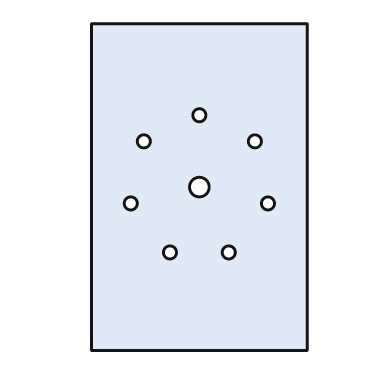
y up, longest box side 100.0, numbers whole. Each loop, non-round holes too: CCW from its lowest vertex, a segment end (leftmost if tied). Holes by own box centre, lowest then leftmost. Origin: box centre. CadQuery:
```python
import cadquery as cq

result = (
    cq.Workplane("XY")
    .moveTo(-33.0, -50.0)
    .lineTo(33.0, -50.0)
    .lineTo(33.0, 50.0)
    .lineTo(-33.0, 50.0)
    .close()
    .moveTo(-9.0, -20.0)
    .circle(2.0)
    .moveTo(9.0, -20.0)
    .circle(2.0)
    .moveTo(-21.0, -5.0)
    .circle(2.0)
    .moveTo(21.0, -5.0)
    .circle(2.0)
    .moveTo(0.0, 0.0)
    .circle(3.0)
    .moveTo(-17.0, 14.0)
    .circle(2.0)
    .moveTo(17.0, 14.0)
    .circle(2.0)
    .moveTo(0.0, 22.0)
    .circle(2.0)
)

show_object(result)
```